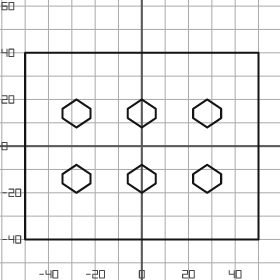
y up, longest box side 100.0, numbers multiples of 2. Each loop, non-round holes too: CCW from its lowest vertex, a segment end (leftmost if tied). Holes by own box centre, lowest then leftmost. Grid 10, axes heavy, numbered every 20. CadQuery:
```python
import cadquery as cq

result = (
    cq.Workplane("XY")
    .moveTo(-50.0, -40.0)
    .lineTo(50.0, -40.0)
    .lineTo(50.0, 40.0)
    .lineTo(-50.0, 40.0)
    .close()
    .moveTo(-28.0, -20.0)
    .lineTo(-22.0, -16.0)
    .lineTo(-22.0, -12.0)
    .lineTo(-28.0, -8.0)
    .lineTo(-34.0, -12.0)
    .lineTo(-34.0, -16.0)
    .close()
    .moveTo(0.0, -20.0)
    .lineTo(6.0, -16.0)
    .lineTo(6.0, -12.0)
    .lineTo(0.0, -8.0)
    .lineTo(-6.0, -12.0)
    .lineTo(-6.0, -16.0)
    .close()
    .moveTo(28.0, -20.0)
    .lineTo(34.0, -16.0)
    .lineTo(34.0, -12.0)
    .lineTo(28.0, -8.0)
    .lineTo(22.0, -12.0)
    .lineTo(22.0, -16.0)
    .close()
    .moveTo(-28.0, 8.0)
    .lineTo(-22.0, 12.0)
    .lineTo(-22.0, 16.0)
    .lineTo(-28.0, 20.0)
    .lineTo(-34.0, 16.0)
    .lineTo(-34.0, 12.0)
    .close()
    .moveTo(0.0, 8.0)
    .lineTo(6.0, 12.0)
    .lineTo(6.0, 16.0)
    .lineTo(0.0, 20.0)
    .lineTo(-6.0, 16.0)
    .lineTo(-6.0, 12.0)
    .close()
    .moveTo(28.0, 8.0)
    .lineTo(34.0, 12.0)
    .lineTo(34.0, 16.0)
    .lineTo(28.0, 20.0)
    .lineTo(22.0, 16.0)
    .lineTo(22.0, 12.0)
    .close()
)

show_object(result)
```